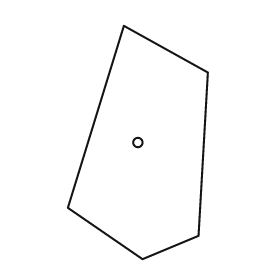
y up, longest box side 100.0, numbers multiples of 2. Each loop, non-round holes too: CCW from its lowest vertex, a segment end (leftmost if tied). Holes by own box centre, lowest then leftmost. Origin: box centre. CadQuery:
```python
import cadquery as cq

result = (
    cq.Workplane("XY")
    .moveTo(2.0, -50.0)
    .lineTo(26.0, -40.0)
    .lineTo(30.0, 30.0)
    .lineTo(-6.0, 50.0)
    .lineTo(-30.0, -28.0)
    .close()
    .moveTo(0.0, 0.0)
    .circle(2.0)
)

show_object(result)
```